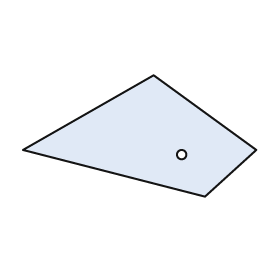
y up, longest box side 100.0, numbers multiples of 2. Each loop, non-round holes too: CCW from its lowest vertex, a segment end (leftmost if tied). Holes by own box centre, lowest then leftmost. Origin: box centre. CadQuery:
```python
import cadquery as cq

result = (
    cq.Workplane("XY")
    .moveTo(28.0, -26.0)
    .lineTo(50.0, -6.0)
    .lineTo(6.0, 26.0)
    .lineTo(-50.0, -6.0)
    .close()
    .moveTo(18.0, -8.0)
    .circle(2.0)
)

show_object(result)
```